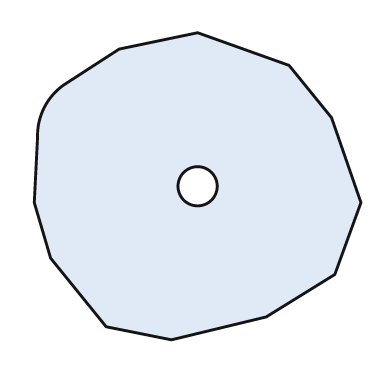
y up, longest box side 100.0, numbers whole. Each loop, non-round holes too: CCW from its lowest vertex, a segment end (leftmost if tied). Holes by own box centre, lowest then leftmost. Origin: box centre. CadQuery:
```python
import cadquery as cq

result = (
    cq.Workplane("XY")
    .moveTo(-8.0, -47.0)
    .lineTo(21.0, -40.0)
    .lineTo(42.0, -27.0)
    .lineTo(50.0, -5.0)
    .lineTo(41.0, 21.0)
    .lineTo(28.0, 37.0)
    .lineTo(0.0, 47.0)
    .lineTo(-24.0, 42.0)
    .lineTo(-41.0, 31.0)
    .threePointArc((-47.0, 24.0), (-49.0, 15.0))
    .lineTo(-50.0, -5.0)
    .lineTo(-45.0, -22.0)
    .lineTo(-28.0, -43.0)
    .close()
    .moveTo(0.0, 0.0)
    .circle(6.0)
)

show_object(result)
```